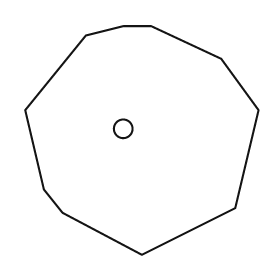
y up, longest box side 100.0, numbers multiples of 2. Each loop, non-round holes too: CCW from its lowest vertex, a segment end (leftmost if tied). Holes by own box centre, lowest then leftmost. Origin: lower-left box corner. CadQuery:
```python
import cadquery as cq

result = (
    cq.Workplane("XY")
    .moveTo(50.0, 0.0)
    .lineTo(90.0, 20.0)
    .lineTo(100.0, 62.0)
    .lineTo(84.0, 84.0)
    .lineTo(54.0, 98.0)
    .lineTo(42.0, 98.0)
    .lineTo(26.0, 94.0)
    .lineTo(0.0, 62.0)
    .lineTo(8.0, 28.0)
    .lineTo(16.0, 18.0)
    .close()
    .moveTo(42.0, 54.0)
    .circle(4.0)
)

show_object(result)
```